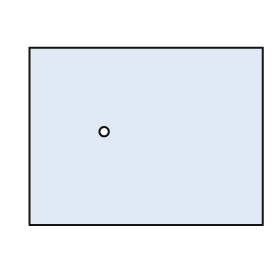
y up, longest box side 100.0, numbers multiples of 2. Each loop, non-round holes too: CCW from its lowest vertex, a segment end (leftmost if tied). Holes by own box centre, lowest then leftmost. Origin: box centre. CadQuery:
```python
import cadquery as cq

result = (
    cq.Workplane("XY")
    .moveTo(-50.0, -38.0)
    .lineTo(50.0, -38.0)
    .lineTo(50.0, 38.0)
    .lineTo(-50.0, 38.0)
    .close()
    .moveTo(-18.0, 2.0)
    .circle(2.0)
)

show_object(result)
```